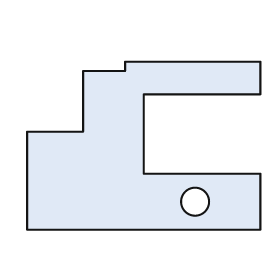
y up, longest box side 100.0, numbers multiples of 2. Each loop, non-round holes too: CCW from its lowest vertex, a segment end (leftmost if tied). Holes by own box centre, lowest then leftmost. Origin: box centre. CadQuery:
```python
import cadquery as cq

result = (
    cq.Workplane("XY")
    .moveTo(-50.0, -36.0)
    .lineTo(50.0, -36.0)
    .lineTo(50.0, -12.0)
    .lineTo(0.0, -12.0)
    .lineTo(0.0, 22.0)
    .lineTo(50.0, 22.0)
    .lineTo(50.0, 36.0)
    .lineTo(-8.0, 36.0)
    .lineTo(-8.0, 32.0)
    .lineTo(-26.0, 32.0)
    .lineTo(-26.0, 6.0)
    .lineTo(-50.0, 6.0)
    .close()
    .moveTo(22.0, -24.0)
    .circle(6.0)
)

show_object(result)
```